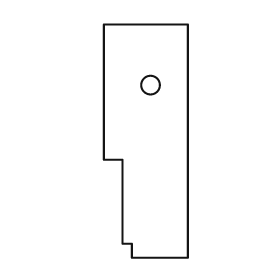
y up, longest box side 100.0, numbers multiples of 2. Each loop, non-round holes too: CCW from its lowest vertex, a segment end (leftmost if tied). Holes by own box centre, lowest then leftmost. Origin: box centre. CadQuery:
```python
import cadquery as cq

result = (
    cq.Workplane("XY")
    .moveTo(-6.0, -50.0)
    .lineTo(18.0, -50.0)
    .lineTo(18.0, 50.0)
    .lineTo(-18.0, 50.0)
    .lineTo(-18.0, -8.0)
    .lineTo(-10.0, -8.0)
    .lineTo(-10.0, -44.0)
    .lineTo(-6.0, -44.0)
    .close()
    .moveTo(2.0, 24.0)
    .circle(4.0)
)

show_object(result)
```